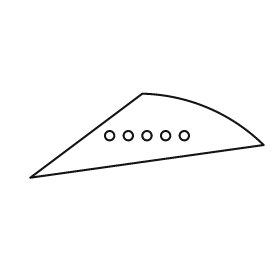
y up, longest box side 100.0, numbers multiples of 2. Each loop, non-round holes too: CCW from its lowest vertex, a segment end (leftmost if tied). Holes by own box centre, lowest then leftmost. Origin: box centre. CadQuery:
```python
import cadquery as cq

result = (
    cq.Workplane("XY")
    .moveTo(-50.0, -18.0)
    .lineTo(50.0, -4.0)
    .threePointArc((26.0, 12.0), (-2.0, 18.0))
    .close()
    .moveTo(-16.0, 0.0)
    .circle(2.0)
    .moveTo(-8.0, 0.0)
    .circle(2.0)
    .moveTo(0.0, 0.0)
    .circle(2.0)
    .moveTo(8.0, 0.0)
    .circle(2.0)
    .moveTo(16.0, 0.0)
    .circle(2.0)
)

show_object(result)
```